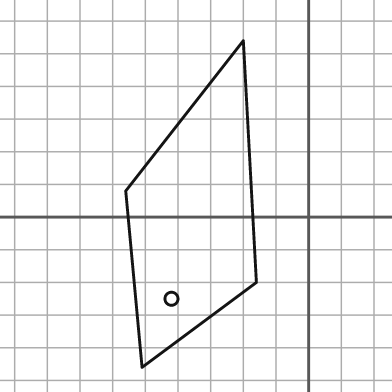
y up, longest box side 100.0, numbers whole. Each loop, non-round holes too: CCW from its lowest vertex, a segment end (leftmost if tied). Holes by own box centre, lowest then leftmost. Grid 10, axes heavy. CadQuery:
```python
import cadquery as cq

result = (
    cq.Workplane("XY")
    .moveTo(-51.0, -46.0)
    .lineTo(-16.0, -20.0)
    .lineTo(-20.0, 54.0)
    .lineTo(-56.0, 8.0)
    .close()
    .moveTo(-42.0, -25.0)
    .circle(2.0)
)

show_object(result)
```